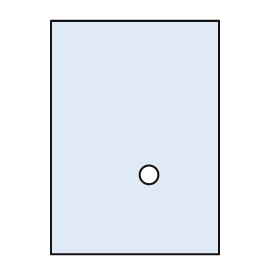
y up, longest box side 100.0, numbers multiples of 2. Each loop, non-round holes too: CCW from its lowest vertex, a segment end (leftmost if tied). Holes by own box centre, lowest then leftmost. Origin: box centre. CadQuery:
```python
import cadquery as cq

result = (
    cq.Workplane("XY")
    .moveTo(-36.0, -50.0)
    .lineTo(36.0, -50.0)
    .lineTo(36.0, 50.0)
    .lineTo(-36.0, 50.0)
    .close()
    .moveTo(6.0, -16.0)
    .circle(4.0)
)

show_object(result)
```